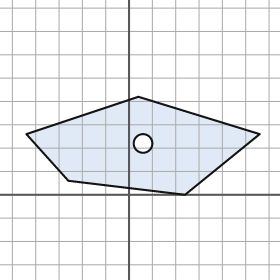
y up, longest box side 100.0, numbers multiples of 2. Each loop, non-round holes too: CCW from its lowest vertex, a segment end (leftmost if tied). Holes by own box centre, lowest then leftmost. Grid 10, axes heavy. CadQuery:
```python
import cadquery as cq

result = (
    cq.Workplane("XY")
    .moveTo(24.0, 0.0)
    .lineTo(56.0, 26.0)
    .lineTo(4.0, 42.0)
    .lineTo(-44.0, 26.0)
    .lineTo(-26.0, 6.0)
    .close()
    .moveTo(6.0, 22.0)
    .circle(4.0)
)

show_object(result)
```